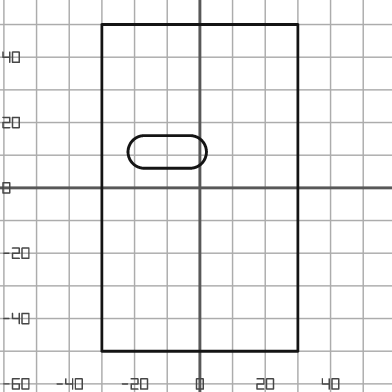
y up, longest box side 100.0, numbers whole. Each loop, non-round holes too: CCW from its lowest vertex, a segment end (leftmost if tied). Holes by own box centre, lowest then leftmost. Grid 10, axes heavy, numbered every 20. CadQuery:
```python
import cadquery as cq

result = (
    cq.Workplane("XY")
    .moveTo(-30.0, -50.0)
    .lineTo(30.0, -50.0)
    .lineTo(30.0, 50.0)
    .lineTo(-30.0, 50.0)
    .close()
    .moveTo(-17.0, 6.0)
    .lineTo(-3.0, 6.0)
    .threePointArc((2.0, 11.0), (-3.0, 16.0))
    .lineTo(-17.0, 16.0)
    .threePointArc((-22.0, 11.0), (-17.0, 6.0))
    .close()
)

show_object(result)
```